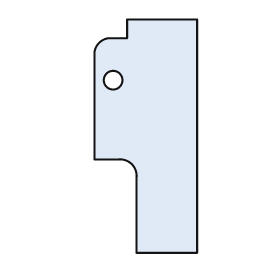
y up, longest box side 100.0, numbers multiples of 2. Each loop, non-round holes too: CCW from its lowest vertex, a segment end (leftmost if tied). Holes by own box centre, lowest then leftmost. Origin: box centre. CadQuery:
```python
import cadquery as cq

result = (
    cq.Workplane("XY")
    .moveTo(-4.0, -50.0)
    .lineTo(22.0, -50.0)
    .lineTo(22.0, 50.0)
    .lineTo(-8.0, 50.0)
    .lineTo(-8.0, 42.0)
    .lineTo(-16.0, 42.0)
    .threePointArc((-20.0, 40.0), (-22.0, 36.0))
    .lineTo(-22.0, -10.0)
    .lineTo(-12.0, -10.0)
    .threePointArc((-6.0, -12.0), (-4.0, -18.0))
    .close()
    .moveTo(-14.0, 24.0)
    .circle(4.0)
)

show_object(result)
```